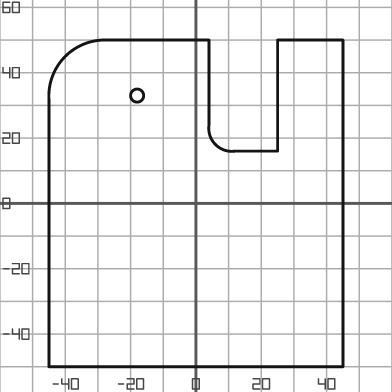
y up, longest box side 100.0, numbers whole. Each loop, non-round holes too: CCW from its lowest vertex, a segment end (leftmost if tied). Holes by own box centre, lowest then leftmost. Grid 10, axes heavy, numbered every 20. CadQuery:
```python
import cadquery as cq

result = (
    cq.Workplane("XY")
    .moveTo(-45.0, -50.0)
    .lineTo(45.0, -50.0)
    .lineTo(45.0, 50.0)
    .lineTo(25.0, 50.0)
    .lineTo(25.0, 16.0)
    .lineTo(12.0, 16.0)
    .threePointArc((6.0, 18.0), (4.0, 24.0))
    .lineTo(4.0, 50.0)
    .lineTo(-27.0, 50.0)
    .threePointArc((-40.0, 45.0), (-45.0, 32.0))
    .close()
    .moveTo(-18.0, 33.0)
    .circle(2.0)
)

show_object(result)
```